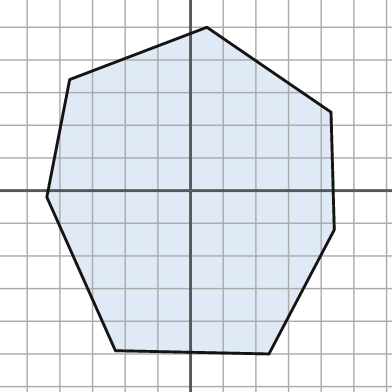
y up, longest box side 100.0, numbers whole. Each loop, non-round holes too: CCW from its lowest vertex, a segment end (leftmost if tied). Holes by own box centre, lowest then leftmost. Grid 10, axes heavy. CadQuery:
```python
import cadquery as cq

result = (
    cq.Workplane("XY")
    .moveTo(24.0, -50.0)
    .lineTo(44.0, -12.0)
    .lineTo(43.0, 24.0)
    .lineTo(5.0, 50.0)
    .lineTo(-37.0, 34.0)
    .lineTo(-44.0, -2.0)
    .lineTo(-23.0, -49.0)
    .close()
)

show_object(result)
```